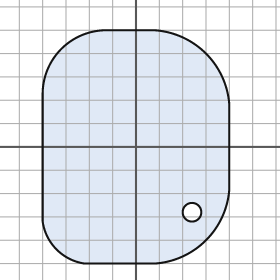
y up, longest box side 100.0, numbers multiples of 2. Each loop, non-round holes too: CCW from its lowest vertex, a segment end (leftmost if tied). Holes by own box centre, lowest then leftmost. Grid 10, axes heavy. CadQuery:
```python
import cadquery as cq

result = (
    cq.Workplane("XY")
    .moveTo(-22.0, -50.0)
    .lineTo(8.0, -50.0)
    .threePointArc((30.0, -40.0), (40.0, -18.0))
    .lineTo(40.0, 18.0)
    .threePointArc((30.0, 40.0), (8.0, 50.0))
    .lineTo(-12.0, 50.0)
    .threePointArc((-32.0, 42.0), (-40.0, 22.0))
    .lineTo(-40.0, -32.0)
    .threePointArc((-34.0, -44.0), (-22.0, -50.0))
    .close()
    .moveTo(24.0, -28.0)
    .circle(4.0)
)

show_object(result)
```